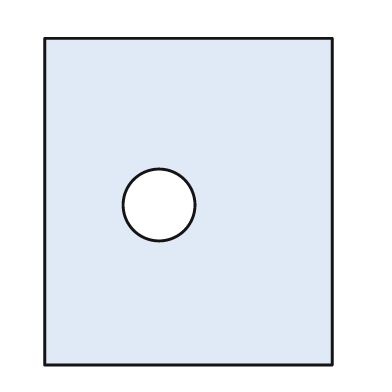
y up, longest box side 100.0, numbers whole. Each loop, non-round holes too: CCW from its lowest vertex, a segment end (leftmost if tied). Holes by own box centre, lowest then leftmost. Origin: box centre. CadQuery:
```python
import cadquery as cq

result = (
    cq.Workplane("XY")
    .moveTo(-44.0, -50.0)
    .lineTo(44.0, -50.0)
    .lineTo(44.0, 50.0)
    .lineTo(-44.0, 50.0)
    .close()
    .moveTo(-9.0, -1.0)
    .circle(11.0)
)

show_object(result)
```